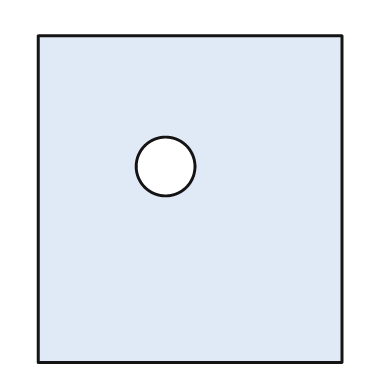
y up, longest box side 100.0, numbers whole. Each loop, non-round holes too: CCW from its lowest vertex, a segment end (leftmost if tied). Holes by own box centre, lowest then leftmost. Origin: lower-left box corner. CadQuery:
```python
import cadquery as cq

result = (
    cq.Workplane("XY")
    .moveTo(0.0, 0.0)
    .lineTo(93.0, 0.0)
    .lineTo(93.0, 100.0)
    .lineTo(0.0, 100.0)
    .close()
    .moveTo(39.0, 60.0)
    .circle(9.0)
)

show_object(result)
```